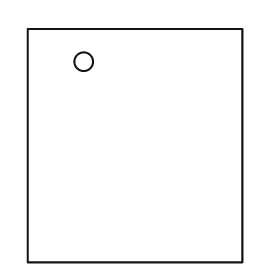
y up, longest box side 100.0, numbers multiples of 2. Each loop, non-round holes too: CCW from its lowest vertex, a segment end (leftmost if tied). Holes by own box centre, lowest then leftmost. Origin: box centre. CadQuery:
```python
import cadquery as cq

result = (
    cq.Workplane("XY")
    .moveTo(-46.0, -50.0)
    .lineTo(46.0, -50.0)
    .lineTo(46.0, 50.0)
    .lineTo(-46.0, 50.0)
    .close()
    .moveTo(-22.0, 36.0)
    .circle(4.0)
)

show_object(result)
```